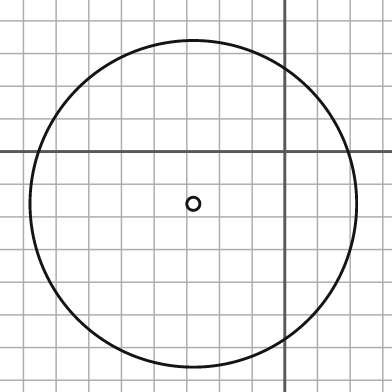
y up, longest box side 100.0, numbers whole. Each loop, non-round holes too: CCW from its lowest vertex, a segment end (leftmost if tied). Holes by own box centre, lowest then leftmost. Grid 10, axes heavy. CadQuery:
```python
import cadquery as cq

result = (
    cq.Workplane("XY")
    .moveTo(-28.0, -16.0)
    .circle(50.0)
    .moveTo(-28.0, -16.0)
    .circle(2.0)
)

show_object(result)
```